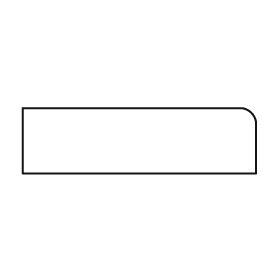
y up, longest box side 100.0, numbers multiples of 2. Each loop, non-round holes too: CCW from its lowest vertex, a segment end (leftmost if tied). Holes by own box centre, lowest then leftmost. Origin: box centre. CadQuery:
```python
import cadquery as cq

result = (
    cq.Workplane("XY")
    .moveTo(-50.0, -14.0)
    .lineTo(50.0, -14.0)
    .lineTo(50.0, 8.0)
    .threePointArc((48.0, 12.0), (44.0, 14.0))
    .lineTo(-50.0, 14.0)
    .close()
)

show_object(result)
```